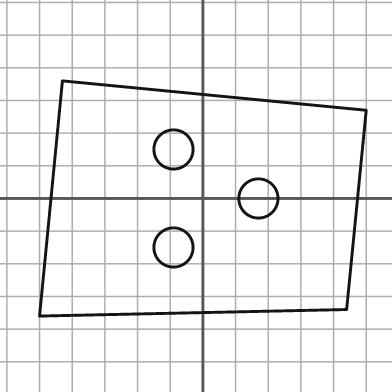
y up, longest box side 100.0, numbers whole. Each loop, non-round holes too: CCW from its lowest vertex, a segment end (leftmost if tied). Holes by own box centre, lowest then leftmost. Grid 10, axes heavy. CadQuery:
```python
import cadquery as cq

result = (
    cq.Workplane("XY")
    .moveTo(-50.0, -36.0)
    .lineTo(44.0, -34.0)
    .lineTo(50.0, 27.0)
    .lineTo(-43.0, 36.0)
    .close()
    .moveTo(-9.0, -15.0)
    .circle(6.0)
    .moveTo(17.0, 0.0)
    .circle(6.0)
    .moveTo(-9.0, 15.0)
    .circle(6.0)
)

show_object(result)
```